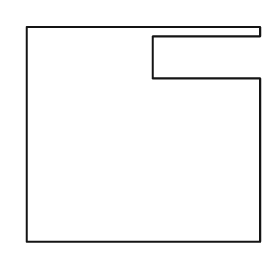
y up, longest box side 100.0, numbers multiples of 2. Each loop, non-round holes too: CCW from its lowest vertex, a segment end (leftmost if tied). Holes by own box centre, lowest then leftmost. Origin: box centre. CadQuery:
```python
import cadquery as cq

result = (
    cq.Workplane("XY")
    .moveTo(-50.0, -46.0)
    .lineTo(50.0, -46.0)
    .lineTo(50.0, 24.0)
    .lineTo(4.0, 24.0)
    .lineTo(4.0, 42.0)
    .lineTo(50.0, 42.0)
    .lineTo(50.0, 46.0)
    .lineTo(-50.0, 46.0)
    .close()
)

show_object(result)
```